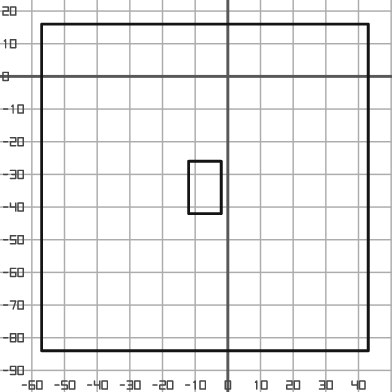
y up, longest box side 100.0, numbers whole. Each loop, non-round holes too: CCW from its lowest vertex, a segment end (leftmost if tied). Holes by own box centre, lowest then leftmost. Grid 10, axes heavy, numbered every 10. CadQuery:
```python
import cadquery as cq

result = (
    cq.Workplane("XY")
    .moveTo(-57.0, -84.0)
    .lineTo(43.0, -84.0)
    .lineTo(43.0, 16.0)
    .lineTo(-57.0, 16.0)
    .close()
    .moveTo(-12.0, -42.0)
    .lineTo(-2.0, -42.0)
    .lineTo(-2.0, -26.0)
    .lineTo(-12.0, -26.0)
    .close()
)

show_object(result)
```